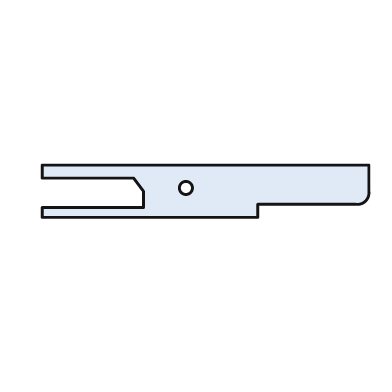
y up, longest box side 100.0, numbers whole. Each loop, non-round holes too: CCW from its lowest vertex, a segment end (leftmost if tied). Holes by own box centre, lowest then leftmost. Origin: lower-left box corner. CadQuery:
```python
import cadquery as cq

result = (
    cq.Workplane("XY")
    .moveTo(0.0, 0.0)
    .lineTo(66.0, 0.0)
    .lineTo(66.0, 4.0)
    .lineTo(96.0, 4.0)
    .threePointArc((99.0, 5.0), (100.0, 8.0))
    .lineTo(100.0, 16.0)
    .lineTo(0.0, 16.0)
    .lineTo(0.0, 12.0)
    .lineTo(28.0, 12.0)
    .lineTo(31.0, 8.0)
    .lineTo(31.0, 3.0)
    .lineTo(0.0, 3.0)
    .close()
    .moveTo(44.0, 9.0)
    .circle(2.0)
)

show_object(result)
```